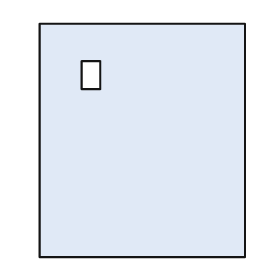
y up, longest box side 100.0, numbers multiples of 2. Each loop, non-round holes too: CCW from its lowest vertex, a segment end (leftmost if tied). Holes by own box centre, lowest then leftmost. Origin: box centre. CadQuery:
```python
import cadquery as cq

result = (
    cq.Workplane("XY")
    .moveTo(-44.0, -50.0)
    .lineTo(44.0, -50.0)
    .lineTo(44.0, 50.0)
    .lineTo(-44.0, 50.0)
    .close()
    .moveTo(-26.0, 22.0)
    .lineTo(-18.0, 22.0)
    .lineTo(-18.0, 34.0)
    .lineTo(-26.0, 34.0)
    .close()
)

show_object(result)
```